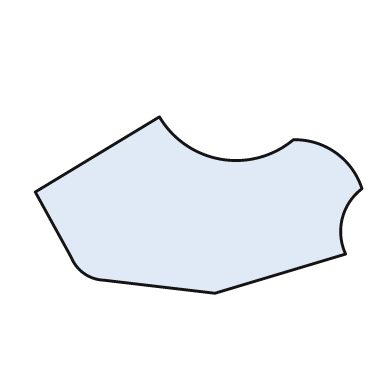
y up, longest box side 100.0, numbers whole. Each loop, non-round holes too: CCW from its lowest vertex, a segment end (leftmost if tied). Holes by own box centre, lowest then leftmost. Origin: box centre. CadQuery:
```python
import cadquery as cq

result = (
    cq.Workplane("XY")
    .moveTo(5.0, -27.0)
    .lineTo(45.0, -15.0)
    .threePointArc((44.0, -4.0), (50.0, 5.0))
    .threePointArc((42.0, 16.0), (29.0, 20.0))
    .threePointArc((7.0, 14.0), (-12.0, 27.0))
    .lineTo(-50.0, 4.0)
    .lineTo(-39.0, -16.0)
    .threePointArc((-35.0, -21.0), (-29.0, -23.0))
    .close()
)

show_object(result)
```